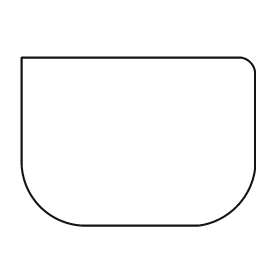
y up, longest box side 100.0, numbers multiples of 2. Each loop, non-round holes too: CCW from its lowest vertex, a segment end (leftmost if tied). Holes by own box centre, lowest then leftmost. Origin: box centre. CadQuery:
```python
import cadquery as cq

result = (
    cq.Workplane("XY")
    .moveTo(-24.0, -36.0)
    .lineTo(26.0, -36.0)
    .threePointArc((42.0, -28.0), (50.0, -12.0))
    .lineTo(50.0, 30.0)
    .threePointArc((48.0, 34.0), (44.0, 36.0))
    .lineTo(-50.0, 36.0)
    .lineTo(-50.0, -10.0)
    .threePointArc((-42.0, -28.0), (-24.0, -36.0))
    .close()
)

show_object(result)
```